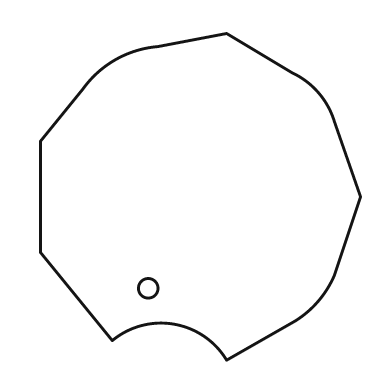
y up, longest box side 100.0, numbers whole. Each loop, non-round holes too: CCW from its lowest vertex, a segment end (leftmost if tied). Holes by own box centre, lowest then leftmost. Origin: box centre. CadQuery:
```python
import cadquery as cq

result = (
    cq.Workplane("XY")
    .moveTo(8.0, -50.0)
    .lineTo(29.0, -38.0)
    .threePointArc((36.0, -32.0), (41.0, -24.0))
    .lineTo(49.0, 0.0)
    .lineTo(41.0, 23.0)
    .threePointArc((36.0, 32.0), (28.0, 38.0))
    .lineTo(8.0, 50.0)
    .lineTo(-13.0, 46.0)
    .threePointArc((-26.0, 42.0), (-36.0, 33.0))
    .lineTo(-49.0, 17.0)
    .lineTo(-49.0, -17.0)
    .lineTo(-27.0, -44.0)
    .threePointArc((-8.0, -39.0), (8.0, -50.0))
    .close()
    .moveTo(-16.0, -28.0)
    .circle(3.0)
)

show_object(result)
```